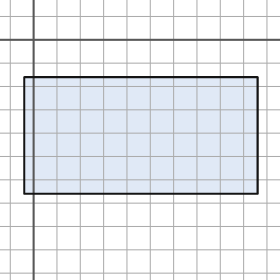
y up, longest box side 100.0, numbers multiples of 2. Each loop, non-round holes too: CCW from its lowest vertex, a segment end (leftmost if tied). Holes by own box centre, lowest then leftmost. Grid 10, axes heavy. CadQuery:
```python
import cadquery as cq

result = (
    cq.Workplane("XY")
    .moveTo(-4.0, -66.0)
    .lineTo(96.0, -66.0)
    .lineTo(96.0, -16.0)
    .lineTo(-4.0, -16.0)
    .close()
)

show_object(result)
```